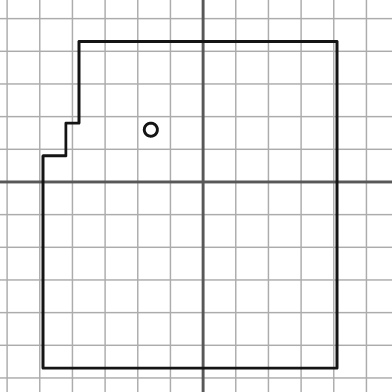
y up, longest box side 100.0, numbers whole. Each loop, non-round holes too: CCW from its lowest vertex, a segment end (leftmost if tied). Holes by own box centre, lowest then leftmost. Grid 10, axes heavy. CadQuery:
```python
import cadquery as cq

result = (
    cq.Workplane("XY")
    .moveTo(-49.0, -57.0)
    .lineTo(41.0, -57.0)
    .lineTo(41.0, 43.0)
    .lineTo(-38.0, 43.0)
    .lineTo(-38.0, 18.0)
    .lineTo(-42.0, 18.0)
    .lineTo(-42.0, 8.0)
    .lineTo(-49.0, 8.0)
    .close()
    .moveTo(-16.0, 16.0)
    .circle(2.0)
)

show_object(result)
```